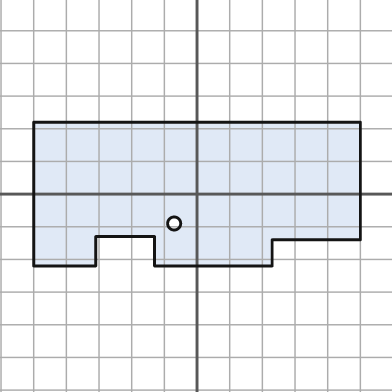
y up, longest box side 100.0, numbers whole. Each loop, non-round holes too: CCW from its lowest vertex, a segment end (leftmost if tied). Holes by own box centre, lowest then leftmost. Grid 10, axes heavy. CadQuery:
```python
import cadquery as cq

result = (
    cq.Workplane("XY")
    .moveTo(-50.0, -22.0)
    .lineTo(-31.0, -22.0)
    .lineTo(-31.0, -13.0)
    .lineTo(-13.0, -13.0)
    .lineTo(-13.0, -22.0)
    .lineTo(23.0, -22.0)
    .lineTo(23.0, -14.0)
    .lineTo(50.0, -14.0)
    .lineTo(50.0, 22.0)
    .lineTo(-50.0, 22.0)
    .close()
    .moveTo(-7.0, -9.0)
    .circle(2.0)
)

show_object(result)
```